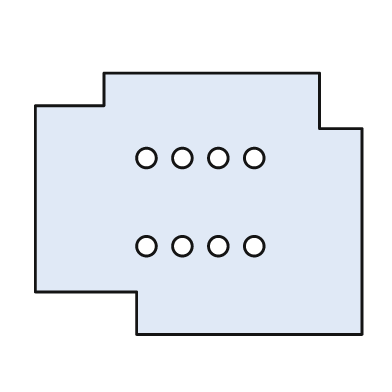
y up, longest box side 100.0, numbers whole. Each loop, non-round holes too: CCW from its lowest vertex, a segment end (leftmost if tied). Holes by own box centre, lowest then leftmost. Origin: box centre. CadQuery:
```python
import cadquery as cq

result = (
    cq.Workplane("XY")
    .moveTo(-19.0, -40.0)
    .lineTo(50.0, -40.0)
    .lineTo(50.0, 23.0)
    .lineTo(37.0, 23.0)
    .lineTo(37.0, 40.0)
    .lineTo(-29.0, 40.0)
    .lineTo(-29.0, 30.0)
    .lineTo(-50.0, 30.0)
    .lineTo(-50.0, -27.0)
    .lineTo(-19.0, -27.0)
    .close()
    .moveTo(-16.0, -13.0)
    .circle(3.0)
    .moveTo(-5.0, -13.0)
    .circle(3.0)
    .moveTo(6.0, -13.0)
    .circle(3.0)
    .moveTo(17.0, -13.0)
    .circle(3.0)
    .moveTo(-16.0, 14.0)
    .circle(3.0)
    .moveTo(-5.0, 14.0)
    .circle(3.0)
    .moveTo(6.0, 14.0)
    .circle(3.0)
    .moveTo(17.0, 14.0)
    .circle(3.0)
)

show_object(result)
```